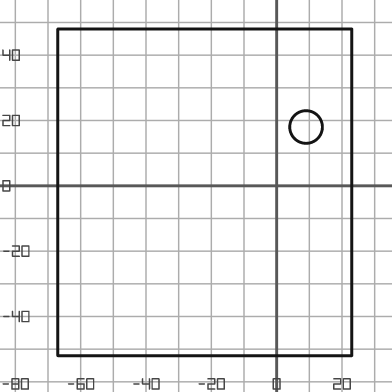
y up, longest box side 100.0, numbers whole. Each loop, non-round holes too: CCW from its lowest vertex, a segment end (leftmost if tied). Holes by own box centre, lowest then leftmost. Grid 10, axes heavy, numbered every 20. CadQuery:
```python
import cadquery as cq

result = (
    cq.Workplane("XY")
    .moveTo(-67.0, -52.0)
    .lineTo(23.0, -52.0)
    .lineTo(23.0, 48.0)
    .lineTo(-67.0, 48.0)
    .close()
    .moveTo(9.0, 18.0)
    .circle(5.0)
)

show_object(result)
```